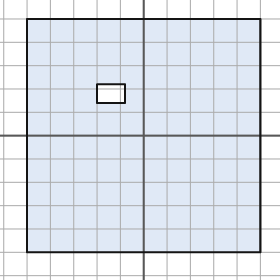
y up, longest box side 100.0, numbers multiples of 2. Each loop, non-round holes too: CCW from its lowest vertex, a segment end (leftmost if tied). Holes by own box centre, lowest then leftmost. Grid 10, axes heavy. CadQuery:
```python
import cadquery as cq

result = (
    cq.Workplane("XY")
    .moveTo(-50.0, -50.0)
    .lineTo(50.0, -50.0)
    .lineTo(50.0, 50.0)
    .lineTo(-50.0, 50.0)
    .close()
    .moveTo(-20.0, 14.0)
    .lineTo(-8.0, 14.0)
    .lineTo(-8.0, 22.0)
    .lineTo(-20.0, 22.0)
    .close()
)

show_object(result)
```